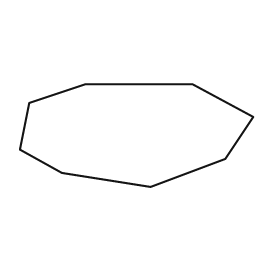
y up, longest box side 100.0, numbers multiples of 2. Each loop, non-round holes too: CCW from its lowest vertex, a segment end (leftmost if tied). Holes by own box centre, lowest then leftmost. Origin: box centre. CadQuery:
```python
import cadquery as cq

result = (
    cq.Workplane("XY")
    .moveTo(6.0, -22.0)
    .lineTo(38.0, -10.0)
    .lineTo(50.0, 8.0)
    .lineTo(24.0, 22.0)
    .lineTo(-22.0, 22.0)
    .lineTo(-46.0, 14.0)
    .lineTo(-50.0, -6.0)
    .lineTo(-32.0, -16.0)
    .close()
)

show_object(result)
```